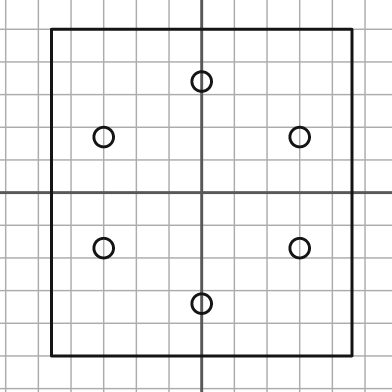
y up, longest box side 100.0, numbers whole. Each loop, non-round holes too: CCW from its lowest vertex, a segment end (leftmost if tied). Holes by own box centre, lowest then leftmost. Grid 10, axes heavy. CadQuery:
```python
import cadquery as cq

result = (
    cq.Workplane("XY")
    .moveTo(-46.0, -50.0)
    .lineTo(46.0, -50.0)
    .lineTo(46.0, 50.0)
    .lineTo(-46.0, 50.0)
    .close()
    .moveTo(0.0, -34.0)
    .circle(3.0)
    .moveTo(-30.0, -17.0)
    .circle(3.0)
    .moveTo(30.0, -17.0)
    .circle(3.0)
    .moveTo(-30.0, 17.0)
    .circle(3.0)
    .moveTo(30.0, 17.0)
    .circle(3.0)
    .moveTo(0.0, 34.0)
    .circle(3.0)
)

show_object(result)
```